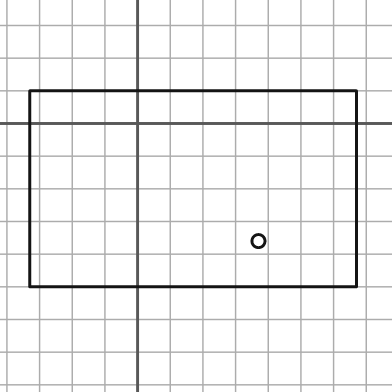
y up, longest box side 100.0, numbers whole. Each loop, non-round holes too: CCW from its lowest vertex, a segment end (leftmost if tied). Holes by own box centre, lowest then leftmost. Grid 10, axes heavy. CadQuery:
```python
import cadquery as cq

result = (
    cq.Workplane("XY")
    .moveTo(-33.0, -50.0)
    .lineTo(67.0, -50.0)
    .lineTo(67.0, 10.0)
    .lineTo(-33.0, 10.0)
    .close()
    .moveTo(37.0, -36.0)
    .circle(2.0)
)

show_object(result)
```